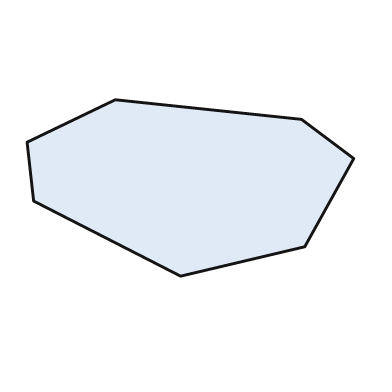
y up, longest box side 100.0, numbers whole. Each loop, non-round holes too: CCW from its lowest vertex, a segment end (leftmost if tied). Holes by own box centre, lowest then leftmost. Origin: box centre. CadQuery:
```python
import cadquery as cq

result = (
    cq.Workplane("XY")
    .moveTo(-3.0, -27.0)
    .lineTo(35.0, -18.0)
    .lineTo(50.0, 9.0)
    .lineTo(34.0, 21.0)
    .lineTo(-23.0, 27.0)
    .lineTo(-50.0, 14.0)
    .lineTo(-48.0, -4.0)
    .close()
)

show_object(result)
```